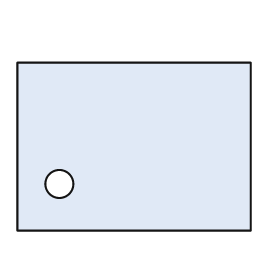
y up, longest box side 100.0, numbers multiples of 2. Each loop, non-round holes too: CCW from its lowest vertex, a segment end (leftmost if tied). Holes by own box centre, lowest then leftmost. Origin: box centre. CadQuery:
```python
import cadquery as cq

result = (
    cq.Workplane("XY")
    .moveTo(-50.0, -36.0)
    .lineTo(50.0, -36.0)
    .lineTo(50.0, 36.0)
    .lineTo(-50.0, 36.0)
    .close()
    .moveTo(-32.0, -16.0)
    .circle(6.0)
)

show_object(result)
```